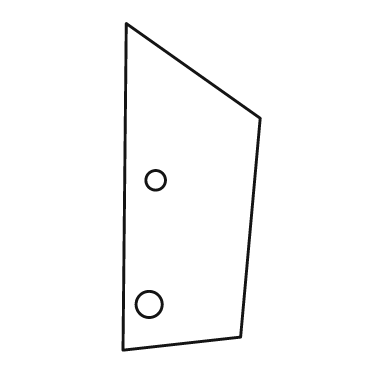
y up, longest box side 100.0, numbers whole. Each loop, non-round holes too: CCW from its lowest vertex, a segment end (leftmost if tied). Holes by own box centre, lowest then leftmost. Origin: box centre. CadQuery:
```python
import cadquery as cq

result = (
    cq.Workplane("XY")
    .moveTo(-21.0, -50.0)
    .lineTo(15.0, -46.0)
    .lineTo(21.0, 21.0)
    .lineTo(-20.0, 50.0)
    .close()
    .moveTo(-13.0, -36.0)
    .circle(4.0)
    .moveTo(-11.0, 2.0)
    .circle(3.0)
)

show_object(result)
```